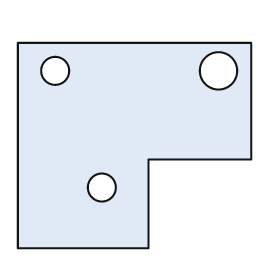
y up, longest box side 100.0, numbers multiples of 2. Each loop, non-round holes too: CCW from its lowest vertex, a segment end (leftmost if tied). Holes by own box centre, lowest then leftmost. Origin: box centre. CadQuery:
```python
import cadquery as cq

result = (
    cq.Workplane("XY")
    .moveTo(-50.0, -44.0)
    .lineTo(6.0, -44.0)
    .lineTo(6.0, -6.0)
    .lineTo(50.0, -6.0)
    .lineTo(50.0, 44.0)
    .lineTo(-50.0, 44.0)
    .close()
    .moveTo(-14.0, -18.0)
    .circle(6.0)
    .moveTo(-34.0, 32.0)
    .circle(6.0)
    .moveTo(36.0, 32.0)
    .circle(8.0)
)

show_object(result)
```